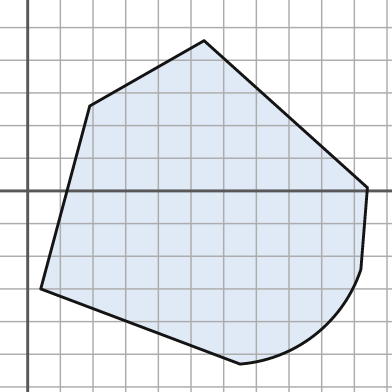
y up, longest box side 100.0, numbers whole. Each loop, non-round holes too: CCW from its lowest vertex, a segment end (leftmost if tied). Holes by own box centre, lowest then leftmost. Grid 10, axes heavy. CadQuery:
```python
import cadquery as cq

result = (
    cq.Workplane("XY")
    .moveTo(65.0, -53.0)
    .threePointArc((88.0, -44.0), (102.0, -24.0))
    .lineTo(104.0, 1.0)
    .lineTo(54.0, 46.0)
    .lineTo(19.0, 26.0)
    .lineTo(4.0, -30.0)
    .close()
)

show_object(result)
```